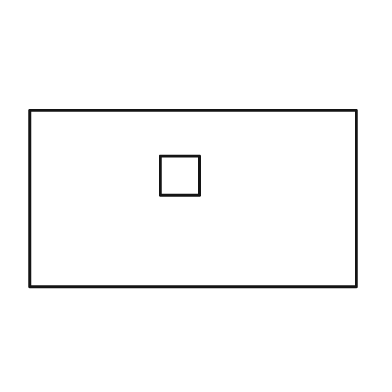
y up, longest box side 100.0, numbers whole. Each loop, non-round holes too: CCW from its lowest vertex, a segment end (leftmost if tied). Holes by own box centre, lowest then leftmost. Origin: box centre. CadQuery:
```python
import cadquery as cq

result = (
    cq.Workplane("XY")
    .moveTo(-50.0, -27.0)
    .lineTo(50.0, -27.0)
    .lineTo(50.0, 27.0)
    .lineTo(-50.0, 27.0)
    .close()
    .moveTo(-10.0, 1.0)
    .lineTo(2.0, 1.0)
    .lineTo(2.0, 13.0)
    .lineTo(-10.0, 13.0)
    .close()
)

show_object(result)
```